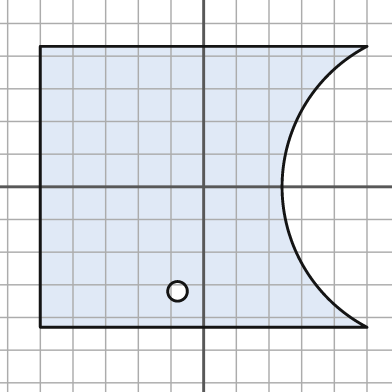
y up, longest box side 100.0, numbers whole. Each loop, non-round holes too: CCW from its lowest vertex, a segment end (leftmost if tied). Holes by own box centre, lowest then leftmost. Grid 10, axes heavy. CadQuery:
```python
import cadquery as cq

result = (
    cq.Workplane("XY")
    .moveTo(-50.0, -43.0)
    .lineTo(50.0, -43.0)
    .threePointArc((24.0, 0.0), (50.0, 43.0))
    .lineTo(-50.0, 43.0)
    .close()
    .moveTo(-8.0, -32.0)
    .circle(3.0)
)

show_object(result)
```